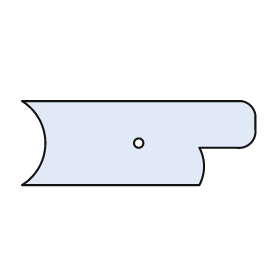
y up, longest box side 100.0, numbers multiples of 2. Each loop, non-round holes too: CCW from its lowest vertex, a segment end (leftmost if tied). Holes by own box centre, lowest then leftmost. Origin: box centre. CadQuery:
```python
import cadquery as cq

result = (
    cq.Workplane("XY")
    .moveTo(-50.0, -18.0)
    .lineTo(26.0, -18.0)
    .threePointArc((28.0, -10.0), (26.0, -2.0))
    .lineTo(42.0, -2.0)
    .threePointArc((48.0, 0.0), (50.0, 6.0))
    .lineTo(50.0, 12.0)
    .threePointArc((48.0, 16.0), (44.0, 18.0))
    .lineTo(-50.0, 18.0)
    .threePointArc((-40.0, 0.0), (-50.0, -18.0))
    .close()
    .moveTo(0.0, 0.0)
    .circle(2.0)
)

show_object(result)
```